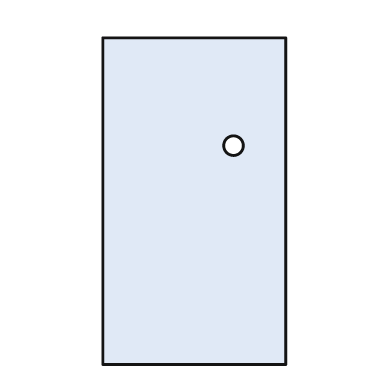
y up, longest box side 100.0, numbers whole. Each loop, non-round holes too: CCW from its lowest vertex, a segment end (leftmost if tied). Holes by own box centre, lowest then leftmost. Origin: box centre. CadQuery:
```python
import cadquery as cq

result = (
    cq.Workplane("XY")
    .moveTo(-28.0, -50.0)
    .lineTo(28.0, -50.0)
    .lineTo(28.0, 50.0)
    .lineTo(-28.0, 50.0)
    .close()
    .moveTo(12.0, 17.0)
    .circle(3.0)
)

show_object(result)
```